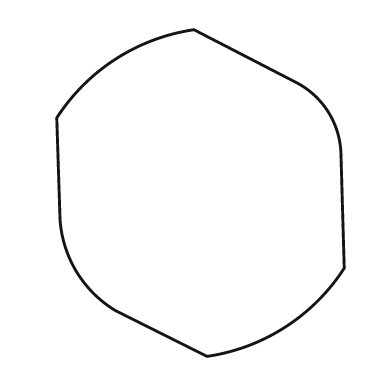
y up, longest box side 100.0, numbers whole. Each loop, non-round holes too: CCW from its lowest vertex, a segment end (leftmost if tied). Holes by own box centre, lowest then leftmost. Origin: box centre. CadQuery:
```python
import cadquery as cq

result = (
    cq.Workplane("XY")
    .moveTo(2.0, -50.0)
    .threePointArc((26.0, -41.0), (44.0, -23.0))
    .lineTo(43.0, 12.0)
    .threePointArc((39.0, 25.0), (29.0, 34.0))
    .lineTo(-2.0, 50.0)
    .threePointArc((-26.0, 41.0), (-44.0, 23.0))
    .lineTo(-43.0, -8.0)
    .threePointArc((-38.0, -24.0), (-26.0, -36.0))
    .close()
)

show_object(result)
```